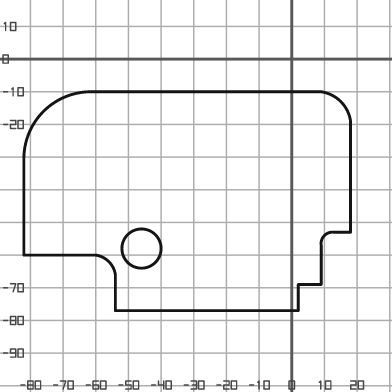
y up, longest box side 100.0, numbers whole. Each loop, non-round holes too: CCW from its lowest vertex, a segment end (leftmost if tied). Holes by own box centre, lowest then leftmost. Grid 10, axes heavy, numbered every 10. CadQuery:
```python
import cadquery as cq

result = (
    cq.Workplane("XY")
    .moveTo(-54.0, -77.0)
    .lineTo(2.0, -77.0)
    .lineTo(2.0, -69.0)
    .lineTo(9.0, -69.0)
    .lineTo(9.0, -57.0)
    .threePointArc((10.0, -54.0), (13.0, -53.0))
    .lineTo(18.0, -53.0)
    .lineTo(18.0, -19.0)
    .threePointArc((15.0, -13.0), (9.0, -10.0))
    .lineTo(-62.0, -10.0)
    .threePointArc((-76.0, -16.0), (-82.0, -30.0))
    .lineTo(-82.0, -60.0)
    .lineTo(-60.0, -60.0)
    .threePointArc((-56.0, -62.0), (-54.0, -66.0))
    .close()
    .moveTo(-46.0, -58.0)
    .circle(6.0)
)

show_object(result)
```